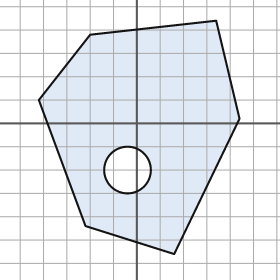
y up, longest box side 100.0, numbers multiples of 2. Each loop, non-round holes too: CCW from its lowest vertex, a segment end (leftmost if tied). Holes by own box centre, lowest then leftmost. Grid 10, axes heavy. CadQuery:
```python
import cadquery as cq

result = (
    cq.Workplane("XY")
    .moveTo(16.0, -56.0)
    .lineTo(44.0, 2.0)
    .lineTo(34.0, 44.0)
    .lineTo(-20.0, 38.0)
    .lineTo(-42.0, 10.0)
    .lineTo(-22.0, -44.0)
    .close()
    .moveTo(-4.0, -20.0)
    .circle(10.0)
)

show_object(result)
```